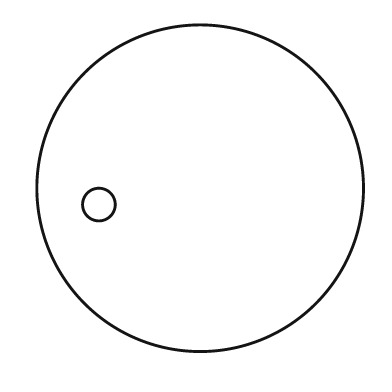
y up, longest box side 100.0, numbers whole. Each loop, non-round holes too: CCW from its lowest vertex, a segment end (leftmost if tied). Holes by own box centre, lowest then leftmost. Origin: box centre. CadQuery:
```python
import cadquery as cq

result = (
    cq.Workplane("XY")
    .moveTo(0.0, 0.0)
    .circle(50.0)
    .moveTo(-31.0, -5.0)
    .circle(5.0)
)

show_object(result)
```